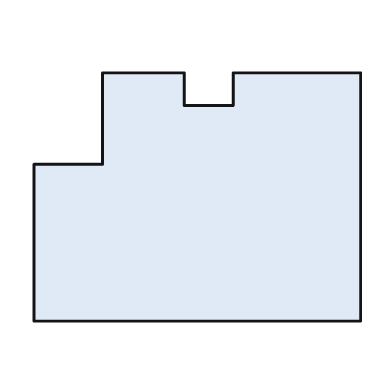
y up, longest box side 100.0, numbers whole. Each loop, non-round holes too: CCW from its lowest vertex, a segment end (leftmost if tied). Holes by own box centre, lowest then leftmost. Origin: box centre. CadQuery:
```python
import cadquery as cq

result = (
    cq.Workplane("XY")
    .moveTo(-50.0, -38.0)
    .lineTo(50.0, -38.0)
    .lineTo(50.0, 38.0)
    .lineTo(11.0, 38.0)
    .lineTo(11.0, 28.0)
    .lineTo(-4.0, 28.0)
    .lineTo(-4.0, 38.0)
    .lineTo(-29.0, 38.0)
    .lineTo(-29.0, 10.0)
    .lineTo(-50.0, 10.0)
    .close()
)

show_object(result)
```